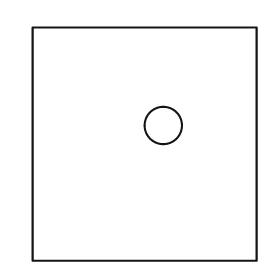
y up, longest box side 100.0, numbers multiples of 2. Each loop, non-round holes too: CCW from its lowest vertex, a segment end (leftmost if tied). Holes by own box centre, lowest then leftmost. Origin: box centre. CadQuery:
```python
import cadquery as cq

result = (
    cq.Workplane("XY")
    .moveTo(-48.0, -50.0)
    .lineTo(48.0, -50.0)
    .lineTo(48.0, 50.0)
    .lineTo(-48.0, 50.0)
    .close()
    .moveTo(8.0, 8.0)
    .circle(8.0)
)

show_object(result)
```